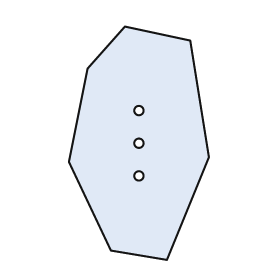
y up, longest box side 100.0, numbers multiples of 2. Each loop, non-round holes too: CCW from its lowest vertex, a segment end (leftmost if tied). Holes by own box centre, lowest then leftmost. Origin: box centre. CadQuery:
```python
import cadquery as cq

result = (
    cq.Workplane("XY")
    .moveTo(12.0, -50.0)
    .lineTo(30.0, -6.0)
    .lineTo(22.0, 44.0)
    .lineTo(-6.0, 50.0)
    .lineTo(-22.0, 32.0)
    .lineTo(-30.0, -8.0)
    .lineTo(-12.0, -46.0)
    .close()
    .moveTo(0.0, -14.0)
    .circle(2.0)
    .moveTo(0.0, 0.0)
    .circle(2.0)
    .moveTo(0.0, 14.0)
    .circle(2.0)
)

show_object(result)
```